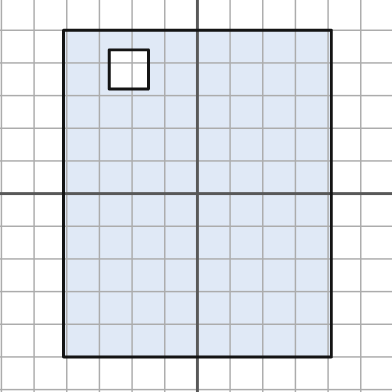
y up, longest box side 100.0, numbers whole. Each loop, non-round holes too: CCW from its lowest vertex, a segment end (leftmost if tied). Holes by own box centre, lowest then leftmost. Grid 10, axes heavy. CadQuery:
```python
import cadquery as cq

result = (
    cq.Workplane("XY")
    .moveTo(-41.0, -50.0)
    .lineTo(41.0, -50.0)
    .lineTo(41.0, 50.0)
    .lineTo(-41.0, 50.0)
    .close()
    .moveTo(-27.0, 32.0)
    .lineTo(-15.0, 32.0)
    .lineTo(-15.0, 44.0)
    .lineTo(-27.0, 44.0)
    .close()
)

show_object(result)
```